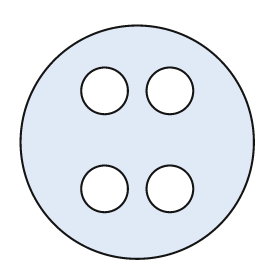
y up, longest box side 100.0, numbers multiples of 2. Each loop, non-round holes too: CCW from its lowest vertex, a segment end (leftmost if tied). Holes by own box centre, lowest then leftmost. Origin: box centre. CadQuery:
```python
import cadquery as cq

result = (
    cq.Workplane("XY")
    .moveTo(0.0, 0.0)
    .circle(50.0)
    .moveTo(-14.0, -20.0)
    .circle(10.0)
    .moveTo(14.0, -20.0)
    .circle(10.0)
    .moveTo(-14.0, 22.0)
    .circle(10.0)
    .moveTo(14.0, 22.0)
    .circle(10.0)
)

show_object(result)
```